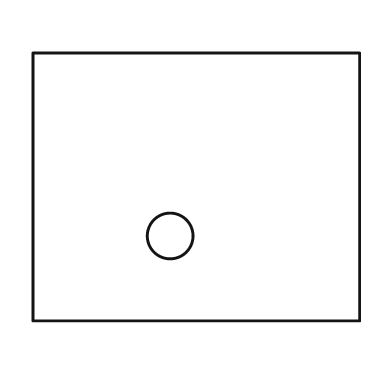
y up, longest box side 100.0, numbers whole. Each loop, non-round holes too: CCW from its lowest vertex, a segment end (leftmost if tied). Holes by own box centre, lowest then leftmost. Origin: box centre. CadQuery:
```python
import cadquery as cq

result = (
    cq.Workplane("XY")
    .moveTo(-50.0, -41.0)
    .lineTo(50.0, -41.0)
    .lineTo(50.0, 41.0)
    .lineTo(-50.0, 41.0)
    .close()
    .moveTo(-8.0, -15.0)
    .circle(7.0)
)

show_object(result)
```